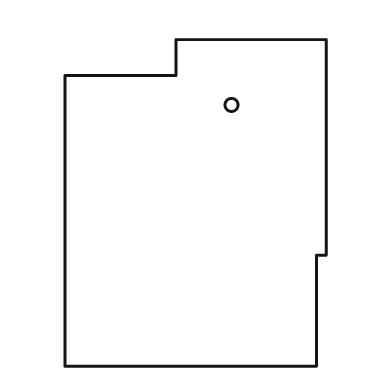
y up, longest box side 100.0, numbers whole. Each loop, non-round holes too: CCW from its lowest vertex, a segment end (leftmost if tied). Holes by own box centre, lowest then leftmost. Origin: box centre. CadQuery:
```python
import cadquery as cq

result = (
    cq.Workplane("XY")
    .moveTo(-40.0, -50.0)
    .lineTo(37.0, -50.0)
    .lineTo(37.0, -16.0)
    .lineTo(40.0, -16.0)
    .lineTo(40.0, 50.0)
    .lineTo(-6.0, 50.0)
    .lineTo(-6.0, 39.0)
    .lineTo(-40.0, 39.0)
    .close()
    .moveTo(11.0, 30.0)
    .circle(2.0)
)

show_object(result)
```